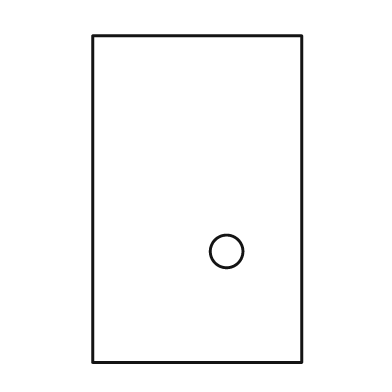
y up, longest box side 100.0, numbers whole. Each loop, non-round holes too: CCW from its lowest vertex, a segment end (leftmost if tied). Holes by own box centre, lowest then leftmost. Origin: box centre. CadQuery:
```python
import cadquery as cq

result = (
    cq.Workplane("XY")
    .moveTo(-32.0, -50.0)
    .lineTo(32.0, -50.0)
    .lineTo(32.0, 50.0)
    .lineTo(-32.0, 50.0)
    .close()
    .moveTo(9.0, -16.0)
    .circle(5.0)
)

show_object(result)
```